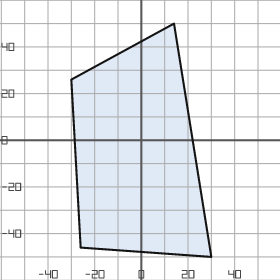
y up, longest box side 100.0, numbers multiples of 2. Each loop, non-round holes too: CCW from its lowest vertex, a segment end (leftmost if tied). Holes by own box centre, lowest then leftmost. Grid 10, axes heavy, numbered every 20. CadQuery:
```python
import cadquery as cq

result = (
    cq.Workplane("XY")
    .moveTo(30.0, -50.0)
    .lineTo(14.0, 50.0)
    .lineTo(-30.0, 26.0)
    .lineTo(-26.0, -46.0)
    .close()
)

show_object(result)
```